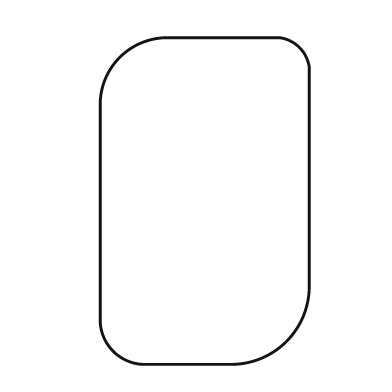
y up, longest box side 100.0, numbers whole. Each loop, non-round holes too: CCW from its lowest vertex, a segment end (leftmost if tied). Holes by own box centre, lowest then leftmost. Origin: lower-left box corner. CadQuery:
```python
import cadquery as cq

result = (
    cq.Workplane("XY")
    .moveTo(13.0, 0.0)
    .lineTo(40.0, 0.0)
    .threePointArc((57.0, 7.0), (64.0, 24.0))
    .lineTo(64.0, 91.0)
    .threePointArc((61.0, 97.0), (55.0, 100.0))
    .lineTo(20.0, 100.0)
    .threePointArc((6.0, 94.0), (0.0, 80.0))
    .lineTo(0.0, 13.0)
    .threePointArc((4.0, 4.0), (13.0, 0.0))
    .close()
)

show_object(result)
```